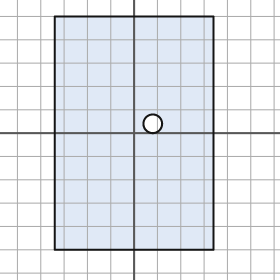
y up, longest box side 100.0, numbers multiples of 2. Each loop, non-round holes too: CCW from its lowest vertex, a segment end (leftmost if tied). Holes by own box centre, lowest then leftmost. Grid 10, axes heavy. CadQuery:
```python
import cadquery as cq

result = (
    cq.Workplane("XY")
    .moveTo(-34.0, -50.0)
    .lineTo(34.0, -50.0)
    .lineTo(34.0, 50.0)
    .lineTo(-34.0, 50.0)
    .close()
    .moveTo(8.0, 4.0)
    .circle(4.0)
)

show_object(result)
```